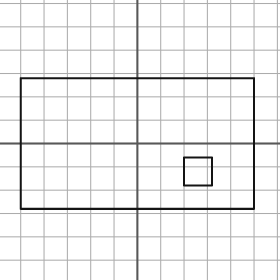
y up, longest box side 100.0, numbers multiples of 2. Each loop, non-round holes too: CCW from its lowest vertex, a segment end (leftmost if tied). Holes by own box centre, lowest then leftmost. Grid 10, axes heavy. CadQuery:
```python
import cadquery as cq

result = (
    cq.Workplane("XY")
    .moveTo(-50.0, -28.0)
    .lineTo(50.0, -28.0)
    .lineTo(50.0, 28.0)
    .lineTo(-50.0, 28.0)
    .close()
    .moveTo(20.0, -18.0)
    .lineTo(32.0, -18.0)
    .lineTo(32.0, -6.0)
    .lineTo(20.0, -6.0)
    .close()
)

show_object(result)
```